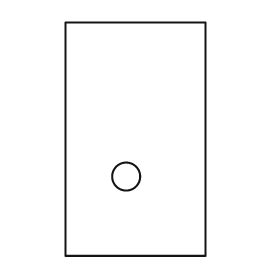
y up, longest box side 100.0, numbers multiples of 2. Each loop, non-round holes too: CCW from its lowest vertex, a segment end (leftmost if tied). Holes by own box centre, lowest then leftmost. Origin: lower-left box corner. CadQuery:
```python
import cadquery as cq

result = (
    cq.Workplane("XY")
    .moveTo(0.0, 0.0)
    .lineTo(60.0, 0.0)
    .lineTo(60.0, 100.0)
    .lineTo(0.0, 100.0)
    .close()
    .moveTo(26.0, 34.0)
    .circle(6.0)
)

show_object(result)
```